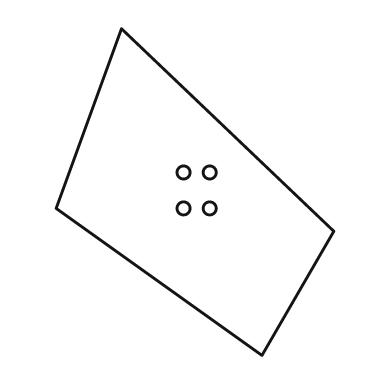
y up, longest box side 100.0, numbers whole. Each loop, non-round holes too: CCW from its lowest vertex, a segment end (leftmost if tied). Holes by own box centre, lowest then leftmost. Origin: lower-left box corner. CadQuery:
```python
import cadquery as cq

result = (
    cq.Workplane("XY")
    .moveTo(63.0, 0.0)
    .lineTo(85.0, 38.0)
    .lineTo(20.0, 100.0)
    .lineTo(0.0, 45.0)
    .close()
    .moveTo(39.0, 45.0)
    .circle(2.0)
    .moveTo(47.0, 45.0)
    .circle(2.0)
    .moveTo(39.0, 56.0)
    .circle(2.0)
    .moveTo(47.0, 56.0)
    .circle(2.0)
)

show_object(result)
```